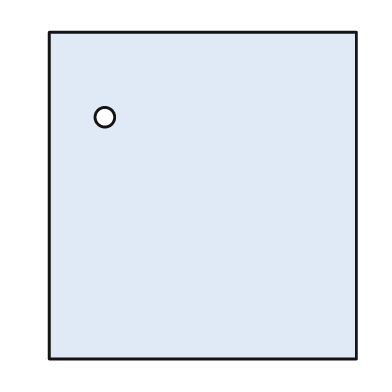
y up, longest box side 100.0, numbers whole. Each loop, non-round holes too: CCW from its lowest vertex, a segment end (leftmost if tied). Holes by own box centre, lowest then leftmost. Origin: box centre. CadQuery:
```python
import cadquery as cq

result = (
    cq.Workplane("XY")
    .moveTo(-47.0, -50.0)
    .lineTo(47.0, -50.0)
    .lineTo(47.0, 50.0)
    .lineTo(-47.0, 50.0)
    .close()
    .moveTo(-30.0, 24.0)
    .circle(3.0)
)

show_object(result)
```